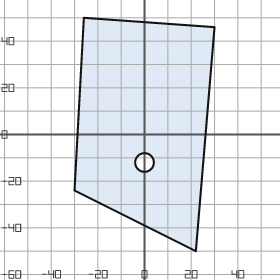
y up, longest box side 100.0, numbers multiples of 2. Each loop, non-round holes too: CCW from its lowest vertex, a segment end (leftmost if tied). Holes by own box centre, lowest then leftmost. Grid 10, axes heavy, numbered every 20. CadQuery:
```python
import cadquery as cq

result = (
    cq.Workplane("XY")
    .moveTo(22.0, -50.0)
    .lineTo(30.0, 46.0)
    .lineTo(-26.0, 50.0)
    .lineTo(-30.0, -24.0)
    .close()
    .moveTo(0.0, -12.0)
    .circle(4.0)
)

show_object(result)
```